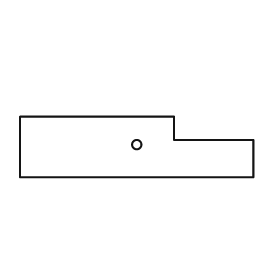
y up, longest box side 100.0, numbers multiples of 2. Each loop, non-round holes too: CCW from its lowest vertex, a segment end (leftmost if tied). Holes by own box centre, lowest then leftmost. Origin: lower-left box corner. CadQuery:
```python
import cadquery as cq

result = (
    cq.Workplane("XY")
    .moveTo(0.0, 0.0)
    .lineTo(100.0, 0.0)
    .lineTo(100.0, 16.0)
    .lineTo(66.0, 16.0)
    .lineTo(66.0, 26.0)
    .lineTo(0.0, 26.0)
    .close()
    .moveTo(50.0, 14.0)
    .circle(2.0)
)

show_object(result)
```